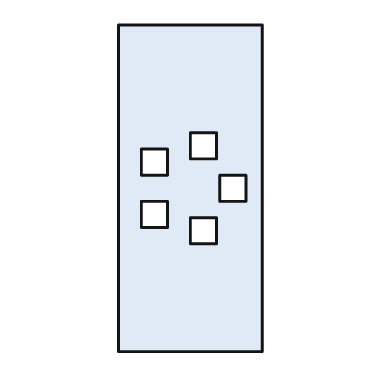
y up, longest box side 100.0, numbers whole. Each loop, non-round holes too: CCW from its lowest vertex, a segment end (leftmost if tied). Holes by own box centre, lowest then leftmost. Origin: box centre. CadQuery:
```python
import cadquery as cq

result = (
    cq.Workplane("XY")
    .moveTo(-22.0, -50.0)
    .lineTo(22.0, -50.0)
    .lineTo(22.0, 50.0)
    .lineTo(-22.0, 50.0)
    .close()
    .moveTo(0.0, -17.0)
    .lineTo(8.0, -17.0)
    .lineTo(8.0, -9.0)
    .lineTo(0.0, -9.0)
    .close()
    .moveTo(-15.0, -12.0)
    .lineTo(-7.0, -12.0)
    .lineTo(-7.0, -4.0)
    .lineTo(-15.0, -4.0)
    .close()
    .moveTo(9.0, -4.0)
    .lineTo(17.0, -4.0)
    .lineTo(17.0, 4.0)
    .lineTo(9.0, 4.0)
    .close()
    .moveTo(-15.0, 4.0)
    .lineTo(-7.0, 4.0)
    .lineTo(-7.0, 12.0)
    .lineTo(-15.0, 12.0)
    .close()
    .moveTo(0.0, 9.0)
    .lineTo(8.0, 9.0)
    .lineTo(8.0, 17.0)
    .lineTo(0.0, 17.0)
    .close()
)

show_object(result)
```